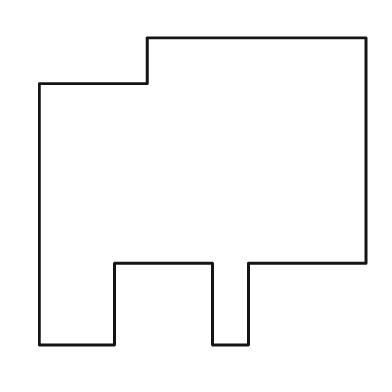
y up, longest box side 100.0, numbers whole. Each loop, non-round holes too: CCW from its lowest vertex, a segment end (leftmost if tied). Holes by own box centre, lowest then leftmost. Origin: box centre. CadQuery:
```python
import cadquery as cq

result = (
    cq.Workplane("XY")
    .moveTo(-50.0, -47.0)
    .lineTo(-27.0, -47.0)
    .lineTo(-27.0, -22.0)
    .lineTo(3.0, -22.0)
    .lineTo(3.0, -47.0)
    .lineTo(14.0, -47.0)
    .lineTo(14.0, -22.0)
    .lineTo(50.0, -22.0)
    .lineTo(50.0, 47.0)
    .lineTo(-17.0, 47.0)
    .lineTo(-17.0, 33.0)
    .lineTo(-50.0, 33.0)
    .close()
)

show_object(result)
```